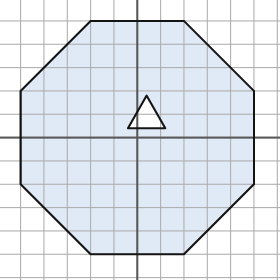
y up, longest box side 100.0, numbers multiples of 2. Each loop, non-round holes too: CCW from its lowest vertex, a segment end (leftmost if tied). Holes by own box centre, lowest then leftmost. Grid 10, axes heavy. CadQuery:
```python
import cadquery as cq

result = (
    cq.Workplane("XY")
    .moveTo(-20.0, -50.0)
    .lineTo(20.0, -50.0)
    .lineTo(50.0, -20.0)
    .lineTo(50.0, 20.0)
    .lineTo(20.0, 50.0)
    .lineTo(-20.0, 50.0)
    .lineTo(-50.0, 20.0)
    .lineTo(-50.0, -20.0)
    .close()
    .moveTo(-4.0, 4.0)
    .lineTo(12.0, 4.0)
    .lineTo(4.0, 18.0)
    .close()
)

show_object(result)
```